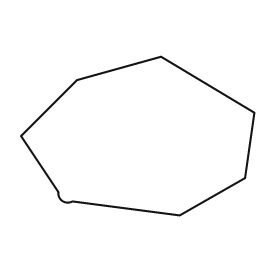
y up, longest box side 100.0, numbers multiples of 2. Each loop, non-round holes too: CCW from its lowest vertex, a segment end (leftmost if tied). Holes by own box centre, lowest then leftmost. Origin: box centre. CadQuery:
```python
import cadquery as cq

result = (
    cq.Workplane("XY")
    .moveTo(18.0, -34.0)
    .lineTo(46.0, -18.0)
    .lineTo(50.0, 10.0)
    .lineTo(10.0, 34.0)
    .lineTo(-26.0, 24.0)
    .lineTo(-50.0, 0.0)
    .lineTo(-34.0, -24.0)
    .threePointArc((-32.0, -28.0), (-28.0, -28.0))
    .close()
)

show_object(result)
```